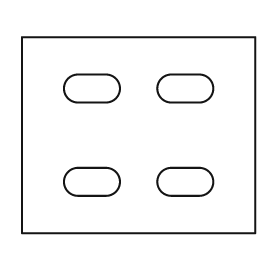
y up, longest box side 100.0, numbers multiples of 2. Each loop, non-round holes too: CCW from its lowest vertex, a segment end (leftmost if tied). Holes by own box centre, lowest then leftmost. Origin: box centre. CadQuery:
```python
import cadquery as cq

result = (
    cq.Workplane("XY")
    .moveTo(-50.0, -42.0)
    .lineTo(50.0, -42.0)
    .lineTo(50.0, 42.0)
    .lineTo(-50.0, 42.0)
    .close()
    .moveTo(-26.0, -26.0)
    .lineTo(-14.0, -26.0)
    .threePointArc((-8.0, -20.0), (-14.0, -14.0))
    .lineTo(-26.0, -14.0)
    .threePointArc((-32.0, -20.0), (-26.0, -26.0))
    .close()
    .moveTo(14.0, -26.0)
    .lineTo(26.0, -26.0)
    .threePointArc((32.0, -20.0), (26.0, -14.0))
    .lineTo(14.0, -14.0)
    .threePointArc((8.0, -20.0), (14.0, -26.0))
    .close()
    .moveTo(-26.0, 14.0)
    .lineTo(-14.0, 14.0)
    .threePointArc((-8.0, 20.0), (-14.0, 26.0))
    .lineTo(-26.0, 26.0)
    .threePointArc((-32.0, 20.0), (-26.0, 14.0))
    .close()
    .moveTo(14.0, 14.0)
    .lineTo(26.0, 14.0)
    .threePointArc((32.0, 20.0), (26.0, 26.0))
    .lineTo(14.0, 26.0)
    .threePointArc((8.0, 20.0), (14.0, 14.0))
    .close()
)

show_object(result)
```